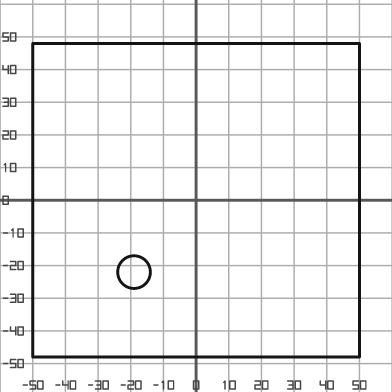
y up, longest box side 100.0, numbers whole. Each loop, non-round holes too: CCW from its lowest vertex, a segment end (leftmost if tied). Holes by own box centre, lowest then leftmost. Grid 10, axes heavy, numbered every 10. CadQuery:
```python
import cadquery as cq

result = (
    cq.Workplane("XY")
    .moveTo(-50.0, -48.0)
    .lineTo(50.0, -48.0)
    .lineTo(50.0, 48.0)
    .lineTo(-50.0, 48.0)
    .close()
    .moveTo(-19.0, -22.0)
    .circle(5.0)
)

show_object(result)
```